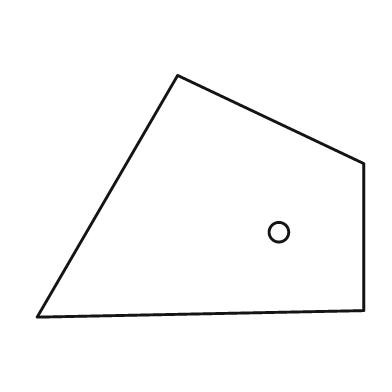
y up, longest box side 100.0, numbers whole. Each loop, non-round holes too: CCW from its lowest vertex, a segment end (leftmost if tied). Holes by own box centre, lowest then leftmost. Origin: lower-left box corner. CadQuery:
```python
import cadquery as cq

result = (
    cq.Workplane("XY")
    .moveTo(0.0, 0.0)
    .lineTo(100.0, 2.0)
    .lineTo(100.0, 47.0)
    .lineTo(43.0, 74.0)
    .close()
    .moveTo(74.0, 26.0)
    .circle(3.0)
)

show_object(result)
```